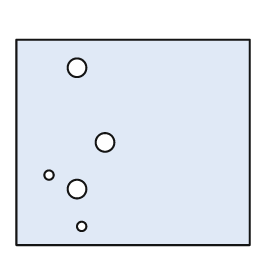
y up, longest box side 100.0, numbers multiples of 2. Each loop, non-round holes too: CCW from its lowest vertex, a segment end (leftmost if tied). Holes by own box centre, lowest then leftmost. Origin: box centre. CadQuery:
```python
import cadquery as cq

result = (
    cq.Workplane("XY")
    .moveTo(-50.0, -44.0)
    .lineTo(50.0, -44.0)
    .lineTo(50.0, 44.0)
    .lineTo(-50.0, 44.0)
    .close()
    .moveTo(-22.0, -36.0)
    .circle(2.0)
    .moveTo(-24.0, -20.0)
    .circle(4.0)
    .moveTo(-36.0, -14.0)
    .circle(2.0)
    .moveTo(-12.0, 0.0)
    .circle(4.0)
    .moveTo(-24.0, 32.0)
    .circle(4.0)
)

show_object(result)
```